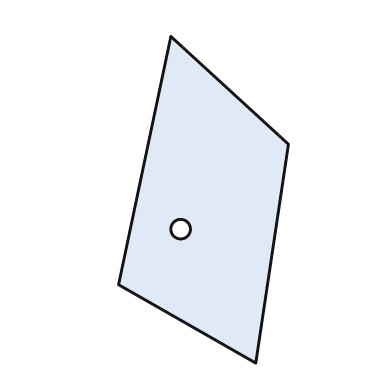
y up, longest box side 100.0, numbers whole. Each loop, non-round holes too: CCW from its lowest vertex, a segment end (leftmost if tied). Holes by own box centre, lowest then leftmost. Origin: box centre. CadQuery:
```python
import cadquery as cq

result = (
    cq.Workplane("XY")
    .moveTo(16.0, -50.0)
    .lineTo(26.0, 17.0)
    .lineTo(-10.0, 50.0)
    .lineTo(-26.0, -26.0)
    .close()
    .moveTo(-7.0, -9.0)
    .circle(3.0)
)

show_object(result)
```